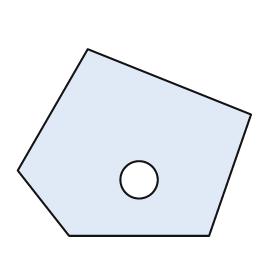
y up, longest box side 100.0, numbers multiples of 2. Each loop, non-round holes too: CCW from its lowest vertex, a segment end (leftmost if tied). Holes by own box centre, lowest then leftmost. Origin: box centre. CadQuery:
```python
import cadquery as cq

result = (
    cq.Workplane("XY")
    .moveTo(-28.0, -40.0)
    .lineTo(32.0, -40.0)
    .lineTo(50.0, 12.0)
    .lineTo(-20.0, 40.0)
    .lineTo(-50.0, -12.0)
    .close()
    .moveTo(2.0, -16.0)
    .circle(8.0)
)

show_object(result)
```